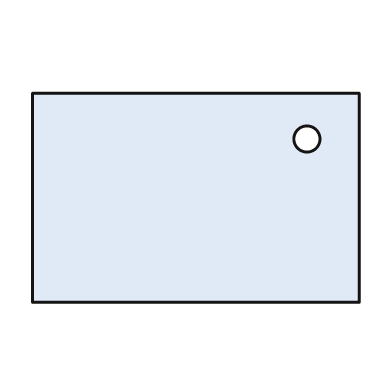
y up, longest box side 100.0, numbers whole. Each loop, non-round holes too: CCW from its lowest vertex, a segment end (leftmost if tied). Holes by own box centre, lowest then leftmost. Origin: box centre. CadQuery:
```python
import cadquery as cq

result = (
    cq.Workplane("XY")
    .moveTo(-50.0, -32.0)
    .lineTo(50.0, -32.0)
    .lineTo(50.0, 32.0)
    .lineTo(-50.0, 32.0)
    .close()
    .moveTo(34.0, 18.0)
    .circle(4.0)
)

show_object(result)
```